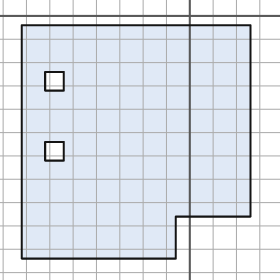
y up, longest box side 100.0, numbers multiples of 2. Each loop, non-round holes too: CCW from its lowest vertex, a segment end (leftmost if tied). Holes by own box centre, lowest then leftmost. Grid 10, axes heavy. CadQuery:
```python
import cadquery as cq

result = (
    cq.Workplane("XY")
    .moveTo(-72.0, -104.0)
    .lineTo(-6.0, -104.0)
    .lineTo(-6.0, -86.0)
    .lineTo(26.0, -86.0)
    .lineTo(26.0, -4.0)
    .lineTo(-72.0, -4.0)
    .close()
    .moveTo(-62.0, -62.0)
    .lineTo(-54.0, -62.0)
    .lineTo(-54.0, -54.0)
    .lineTo(-62.0, -54.0)
    .close()
    .moveTo(-62.0, -32.0)
    .lineTo(-54.0, -32.0)
    .lineTo(-54.0, -24.0)
    .lineTo(-62.0, -24.0)
    .close()
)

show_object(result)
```